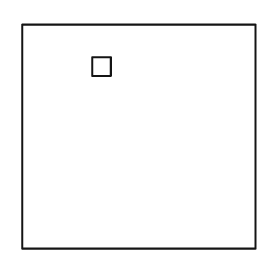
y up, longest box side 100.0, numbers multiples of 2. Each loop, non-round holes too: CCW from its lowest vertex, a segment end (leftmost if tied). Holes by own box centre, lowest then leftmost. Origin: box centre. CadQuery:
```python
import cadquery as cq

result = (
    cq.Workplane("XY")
    .moveTo(-50.0, -48.0)
    .lineTo(50.0, -48.0)
    .lineTo(50.0, 48.0)
    .lineTo(-50.0, 48.0)
    .close()
    .moveTo(-20.0, 26.0)
    .lineTo(-12.0, 26.0)
    .lineTo(-12.0, 34.0)
    .lineTo(-20.0, 34.0)
    .close()
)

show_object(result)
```